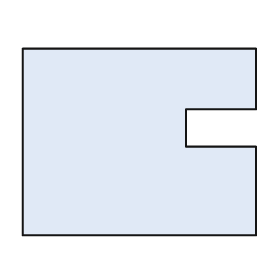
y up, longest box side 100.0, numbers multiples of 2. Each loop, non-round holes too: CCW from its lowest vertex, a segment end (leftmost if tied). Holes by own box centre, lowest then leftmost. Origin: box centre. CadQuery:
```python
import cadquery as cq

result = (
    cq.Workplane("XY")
    .moveTo(-50.0, -40.0)
    .lineTo(50.0, -40.0)
    .lineTo(50.0, -2.0)
    .lineTo(20.0, -2.0)
    .lineTo(20.0, 14.0)
    .lineTo(50.0, 14.0)
    .lineTo(50.0, 40.0)
    .lineTo(-50.0, 40.0)
    .close()
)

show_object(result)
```